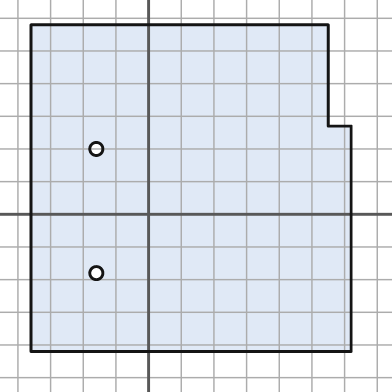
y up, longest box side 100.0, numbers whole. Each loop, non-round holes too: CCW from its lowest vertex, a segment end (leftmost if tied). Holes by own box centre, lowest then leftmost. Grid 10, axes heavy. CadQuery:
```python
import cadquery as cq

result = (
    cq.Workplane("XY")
    .moveTo(-36.0, -42.0)
    .lineTo(62.0, -42.0)
    .lineTo(62.0, 27.0)
    .lineTo(55.0, 27.0)
    .lineTo(55.0, 58.0)
    .lineTo(-36.0, 58.0)
    .close()
    .moveTo(-16.0, -18.0)
    .circle(2.0)
    .moveTo(-16.0, 20.0)
    .circle(2.0)
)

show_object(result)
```